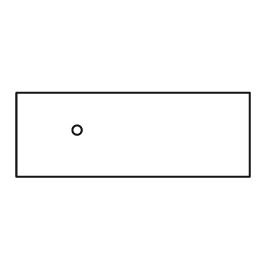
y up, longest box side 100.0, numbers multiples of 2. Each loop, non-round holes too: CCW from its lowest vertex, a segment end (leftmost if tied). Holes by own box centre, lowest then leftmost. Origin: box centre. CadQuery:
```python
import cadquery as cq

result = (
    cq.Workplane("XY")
    .moveTo(-50.0, -18.0)
    .lineTo(50.0, -18.0)
    .lineTo(50.0, 18.0)
    .lineTo(-50.0, 18.0)
    .close()
    .moveTo(-24.0, 2.0)
    .circle(2.0)
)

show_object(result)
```